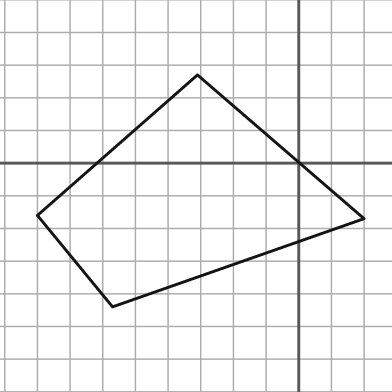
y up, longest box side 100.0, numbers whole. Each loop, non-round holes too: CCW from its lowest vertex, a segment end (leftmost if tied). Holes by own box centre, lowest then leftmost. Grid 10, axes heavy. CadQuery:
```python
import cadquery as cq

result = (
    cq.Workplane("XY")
    .moveTo(-57.0, -44.0)
    .lineTo(20.0, -17.0)
    .lineTo(-31.0, 27.0)
    .lineTo(-80.0, -16.0)
    .close()
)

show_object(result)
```